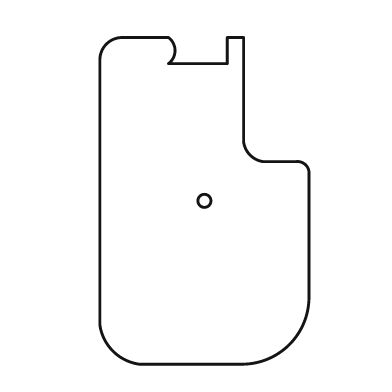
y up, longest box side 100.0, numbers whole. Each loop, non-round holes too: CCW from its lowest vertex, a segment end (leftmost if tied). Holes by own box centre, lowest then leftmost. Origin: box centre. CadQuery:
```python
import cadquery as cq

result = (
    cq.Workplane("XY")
    .moveTo(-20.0, -50.0)
    .lineTo(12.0, -50.0)
    .threePointArc((26.0, -44.0), (32.0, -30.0))
    .lineTo(32.0, 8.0)
    .threePointArc((31.0, 11.0), (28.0, 12.0))
    .lineTo(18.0, 12.0)
    .threePointArc((14.0, 14.0), (12.0, 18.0))
    .lineTo(12.0, 50.0)
    .lineTo(7.0, 50.0)
    .lineTo(7.0, 42.0)
    .lineTo(-11.0, 42.0)
    .threePointArc((-9.0, 46.0), (-11.0, 50.0))
    .lineTo(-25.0, 50.0)
    .threePointArc((-30.0, 48.0), (-32.0, 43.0))
    .lineTo(-32.0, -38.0)
    .threePointArc((-28.0, -46.0), (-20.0, -50.0))
    .close()
    .moveTo(0.0, 0.0)
    .circle(2.0)
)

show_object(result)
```